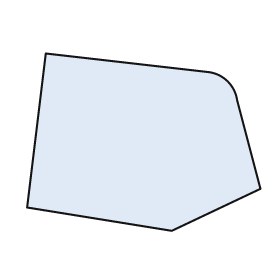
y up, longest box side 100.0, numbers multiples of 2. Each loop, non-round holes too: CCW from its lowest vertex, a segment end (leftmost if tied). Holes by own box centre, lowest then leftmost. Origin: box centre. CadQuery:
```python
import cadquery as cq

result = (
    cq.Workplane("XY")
    .moveTo(12.0, -38.0)
    .lineTo(50.0, -20.0)
    .lineTo(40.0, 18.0)
    .threePointArc((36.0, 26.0), (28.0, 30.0))
    .lineTo(-42.0, 38.0)
    .lineTo(-50.0, -28.0)
    .close()
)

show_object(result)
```